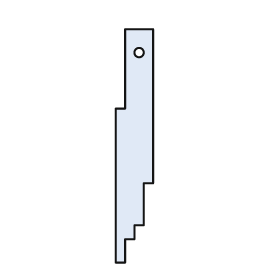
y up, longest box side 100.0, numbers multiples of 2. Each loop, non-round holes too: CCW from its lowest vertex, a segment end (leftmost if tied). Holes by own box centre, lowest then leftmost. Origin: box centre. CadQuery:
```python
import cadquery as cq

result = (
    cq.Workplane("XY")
    .moveTo(-8.0, -50.0)
    .lineTo(-4.0, -50.0)
    .lineTo(-4.0, -40.0)
    .lineTo(0.0, -40.0)
    .lineTo(0.0, -34.0)
    .lineTo(4.0, -34.0)
    .lineTo(4.0, -16.0)
    .lineTo(8.0, -16.0)
    .lineTo(8.0, 50.0)
    .lineTo(-4.0, 50.0)
    .lineTo(-4.0, 16.0)
    .lineTo(-8.0, 16.0)
    .close()
    .moveTo(2.0, 40.0)
    .circle(2.0)
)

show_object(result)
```